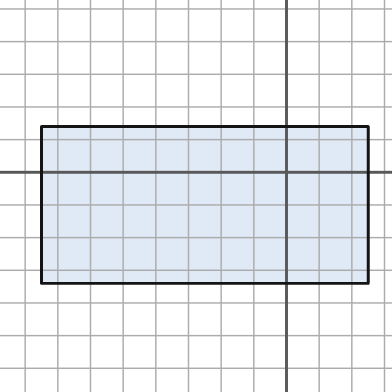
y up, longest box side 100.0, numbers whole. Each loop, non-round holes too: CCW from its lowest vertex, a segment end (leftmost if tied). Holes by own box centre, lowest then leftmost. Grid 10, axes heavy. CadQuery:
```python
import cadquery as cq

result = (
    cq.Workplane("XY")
    .moveTo(-75.0, -34.0)
    .lineTo(25.0, -34.0)
    .lineTo(25.0, 14.0)
    .lineTo(-75.0, 14.0)
    .close()
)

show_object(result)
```